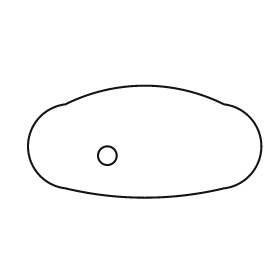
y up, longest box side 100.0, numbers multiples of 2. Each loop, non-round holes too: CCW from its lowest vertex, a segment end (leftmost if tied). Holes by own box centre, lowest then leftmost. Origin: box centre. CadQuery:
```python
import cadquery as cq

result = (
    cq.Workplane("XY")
    .moveTo(-34.0, -20.0)
    .threePointArc((0.0, -24.0), (34.0, -20.0))
    .threePointArc((50.0, -2.0), (34.0, 16.0))
    .threePointArc((0.0, 24.0), (-34.0, 16.0))
    .threePointArc((-50.0, -2.0), (-34.0, -20.0))
    .close()
    .moveTo(-16.0, -6.0)
    .circle(4.0)
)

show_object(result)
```